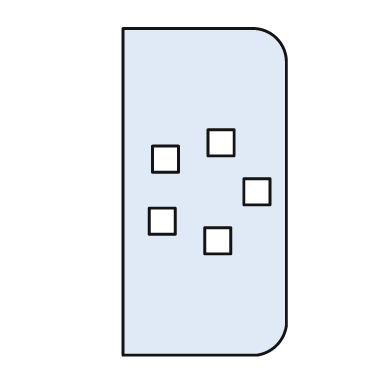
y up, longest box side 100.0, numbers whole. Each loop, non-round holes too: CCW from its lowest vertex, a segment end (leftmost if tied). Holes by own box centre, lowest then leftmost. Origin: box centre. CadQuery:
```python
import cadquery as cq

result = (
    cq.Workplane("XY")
    .moveTo(-25.0, -50.0)
    .lineTo(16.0, -50.0)
    .threePointArc((22.0, -47.0), (25.0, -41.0))
    .lineTo(25.0, 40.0)
    .threePointArc((22.0, 47.0), (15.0, 50.0))
    .lineTo(-25.0, 50.0)
    .close()
    .moveTo(0.0, -19.0)
    .lineTo(8.0, -19.0)
    .lineTo(8.0, -11.0)
    .lineTo(0.0, -11.0)
    .close()
    .moveTo(-17.0, -13.0)
    .lineTo(-9.0, -13.0)
    .lineTo(-9.0, -5.0)
    .lineTo(-17.0, -5.0)
    .close()
    .moveTo(12.0, -4.0)
    .lineTo(20.0, -4.0)
    .lineTo(20.0, 4.0)
    .lineTo(12.0, 4.0)
    .close()
    .moveTo(-16.0, 6.0)
    .lineTo(-8.0, 6.0)
    .lineTo(-8.0, 14.0)
    .lineTo(-16.0, 14.0)
    .close()
    .moveTo(1.0, 11.0)
    .lineTo(9.0, 11.0)
    .lineTo(9.0, 19.0)
    .lineTo(1.0, 19.0)
    .close()
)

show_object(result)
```